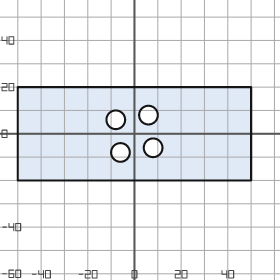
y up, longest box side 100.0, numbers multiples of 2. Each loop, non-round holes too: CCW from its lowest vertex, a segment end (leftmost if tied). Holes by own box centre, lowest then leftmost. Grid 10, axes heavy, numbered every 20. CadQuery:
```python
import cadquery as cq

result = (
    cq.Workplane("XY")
    .moveTo(-50.0, -20.0)
    .lineTo(50.0, -20.0)
    .lineTo(50.0, 20.0)
    .lineTo(-50.0, 20.0)
    .close()
    .moveTo(-6.0, -8.0)
    .circle(4.0)
    .moveTo(8.0, -6.0)
    .circle(4.0)
    .moveTo(-8.0, 6.0)
    .circle(4.0)
    .moveTo(6.0, 8.0)
    .circle(4.0)
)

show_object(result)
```